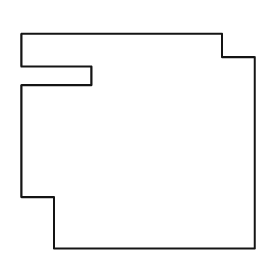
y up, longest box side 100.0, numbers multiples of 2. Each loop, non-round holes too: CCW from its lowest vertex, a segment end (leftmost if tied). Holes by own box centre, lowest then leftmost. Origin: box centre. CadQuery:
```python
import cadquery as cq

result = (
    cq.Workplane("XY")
    .moveTo(-36.0, -46.0)
    .lineTo(50.0, -46.0)
    .lineTo(50.0, 36.0)
    .lineTo(36.0, 36.0)
    .lineTo(36.0, 46.0)
    .lineTo(-50.0, 46.0)
    .lineTo(-50.0, 32.0)
    .lineTo(-20.0, 32.0)
    .lineTo(-20.0, 24.0)
    .lineTo(-50.0, 24.0)
    .lineTo(-50.0, -24.0)
    .lineTo(-36.0, -24.0)
    .close()
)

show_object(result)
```